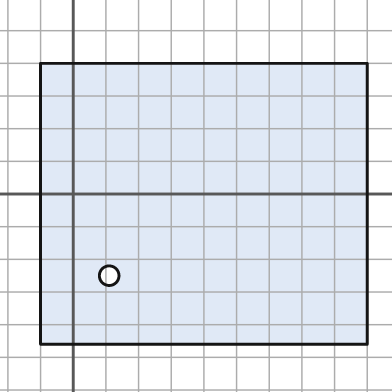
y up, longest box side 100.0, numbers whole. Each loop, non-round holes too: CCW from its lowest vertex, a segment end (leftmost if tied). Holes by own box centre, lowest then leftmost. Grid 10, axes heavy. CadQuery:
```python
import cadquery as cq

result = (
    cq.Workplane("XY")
    .moveTo(-10.0, -46.0)
    .lineTo(90.0, -46.0)
    .lineTo(90.0, 40.0)
    .lineTo(-10.0, 40.0)
    .close()
    .moveTo(11.0, -25.0)
    .circle(3.0)
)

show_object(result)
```